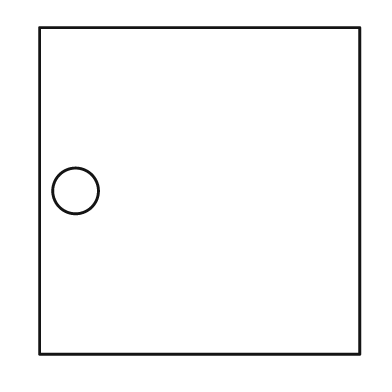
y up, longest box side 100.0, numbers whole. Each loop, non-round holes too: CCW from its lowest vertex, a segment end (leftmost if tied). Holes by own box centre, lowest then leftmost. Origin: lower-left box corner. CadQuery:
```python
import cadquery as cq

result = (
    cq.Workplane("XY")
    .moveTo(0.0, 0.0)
    .lineTo(98.0, 0.0)
    .lineTo(98.0, 100.0)
    .lineTo(0.0, 100.0)
    .close()
    .moveTo(11.0, 50.0)
    .circle(7.0)
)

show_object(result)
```